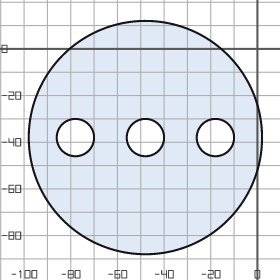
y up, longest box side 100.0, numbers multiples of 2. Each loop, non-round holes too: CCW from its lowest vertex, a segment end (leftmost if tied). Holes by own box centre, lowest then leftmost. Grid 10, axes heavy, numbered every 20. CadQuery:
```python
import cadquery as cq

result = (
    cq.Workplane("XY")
    .moveTo(-48.0, -38.0)
    .circle(50.0)
    .moveTo(-78.0, -38.0)
    .circle(8.0)
    .moveTo(-48.0, -38.0)
    .circle(8.0)
    .moveTo(-18.0, -38.0)
    .circle(8.0)
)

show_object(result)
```